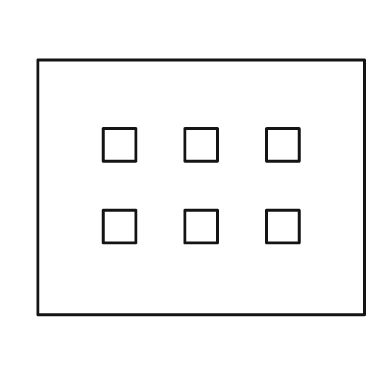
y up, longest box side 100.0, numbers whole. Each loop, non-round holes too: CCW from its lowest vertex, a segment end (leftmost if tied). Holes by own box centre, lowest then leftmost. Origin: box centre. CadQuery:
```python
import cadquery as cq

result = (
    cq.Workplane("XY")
    .moveTo(-50.0, -39.0)
    .lineTo(50.0, -39.0)
    .lineTo(50.0, 39.0)
    .lineTo(-50.0, 39.0)
    .close()
    .moveTo(-30.0, -17.0)
    .lineTo(-20.0, -17.0)
    .lineTo(-20.0, -7.0)
    .lineTo(-30.0, -7.0)
    .close()
    .moveTo(-5.0, -17.0)
    .lineTo(5.0, -17.0)
    .lineTo(5.0, -7.0)
    .lineTo(-5.0, -7.0)
    .close()
    .moveTo(20.0, -17.0)
    .lineTo(30.0, -17.0)
    .lineTo(30.0, -7.0)
    .lineTo(20.0, -7.0)
    .close()
    .moveTo(-30.0, 8.0)
    .lineTo(-20.0, 8.0)
    .lineTo(-20.0, 18.0)
    .lineTo(-30.0, 18.0)
    .close()
    .moveTo(-5.0, 8.0)
    .lineTo(5.0, 8.0)
    .lineTo(5.0, 18.0)
    .lineTo(-5.0, 18.0)
    .close()
    .moveTo(20.0, 8.0)
    .lineTo(30.0, 8.0)
    .lineTo(30.0, 18.0)
    .lineTo(20.0, 18.0)
    .close()
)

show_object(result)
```